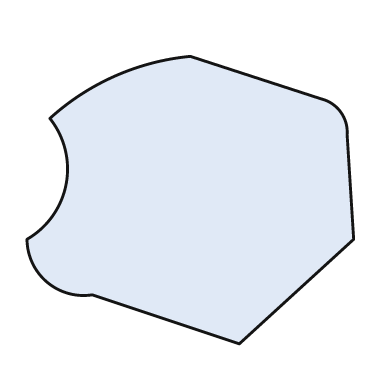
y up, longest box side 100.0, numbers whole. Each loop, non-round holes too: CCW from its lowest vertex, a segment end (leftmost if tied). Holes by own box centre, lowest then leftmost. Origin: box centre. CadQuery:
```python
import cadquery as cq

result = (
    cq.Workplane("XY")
    .moveTo(15.0, -44.0)
    .lineTo(50.0, -12.0)
    .lineTo(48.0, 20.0)
    .threePointArc((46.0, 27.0), (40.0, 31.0))
    .lineTo(0.0, 44.0)
    .threePointArc((-23.0, 38.0), (-43.0, 25.0))
    .threePointArc((-38.0, 5.0), (-50.0, -12.0))
    .threePointArc((-44.0, -25.0), (-30.0, -29.0))
    .close()
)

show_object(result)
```